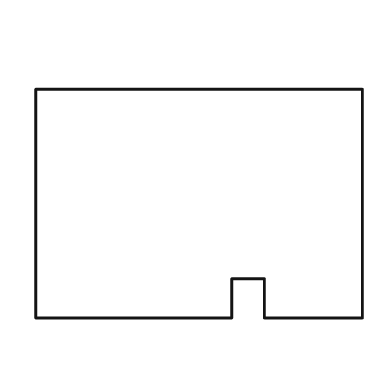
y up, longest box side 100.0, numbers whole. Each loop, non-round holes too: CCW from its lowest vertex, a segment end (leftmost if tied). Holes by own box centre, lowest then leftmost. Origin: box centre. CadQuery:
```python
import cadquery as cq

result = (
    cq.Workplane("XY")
    .moveTo(-50.0, -35.0)
    .lineTo(10.0, -35.0)
    .lineTo(10.0, -23.0)
    .lineTo(20.0, -23.0)
    .lineTo(20.0, -35.0)
    .lineTo(50.0, -35.0)
    .lineTo(50.0, 35.0)
    .lineTo(-50.0, 35.0)
    .close()
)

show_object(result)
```